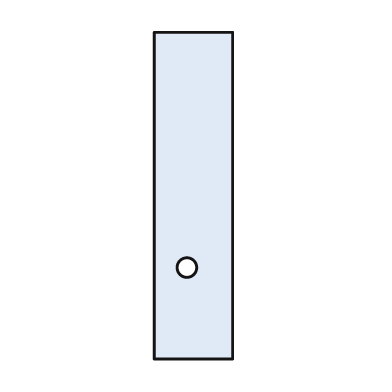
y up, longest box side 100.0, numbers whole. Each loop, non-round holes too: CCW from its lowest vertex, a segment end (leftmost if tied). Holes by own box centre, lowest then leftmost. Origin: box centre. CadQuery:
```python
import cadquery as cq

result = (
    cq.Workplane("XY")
    .moveTo(-12.0, -50.0)
    .lineTo(12.0, -50.0)
    .lineTo(12.0, 50.0)
    .lineTo(-12.0, 50.0)
    .close()
    .moveTo(-2.0, -22.0)
    .circle(3.0)
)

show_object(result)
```